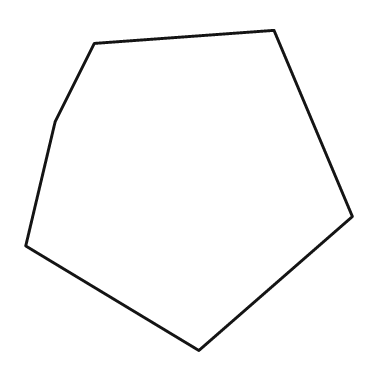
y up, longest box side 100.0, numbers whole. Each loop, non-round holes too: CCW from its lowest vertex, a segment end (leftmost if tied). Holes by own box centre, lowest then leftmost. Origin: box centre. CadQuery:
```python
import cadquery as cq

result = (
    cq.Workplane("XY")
    .moveTo(3.0, -49.0)
    .lineTo(50.0, -8.0)
    .lineTo(26.0, 49.0)
    .lineTo(-29.0, 45.0)
    .lineTo(-41.0, 21.0)
    .lineTo(-50.0, -17.0)
    .close()
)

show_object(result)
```